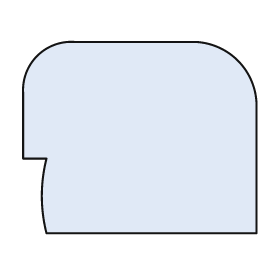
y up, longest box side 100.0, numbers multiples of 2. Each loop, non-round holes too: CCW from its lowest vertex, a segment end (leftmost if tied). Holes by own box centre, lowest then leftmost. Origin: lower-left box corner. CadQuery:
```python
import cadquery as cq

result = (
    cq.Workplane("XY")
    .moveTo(10.0, 0.0)
    .lineTo(100.0, 0.0)
    .lineTo(100.0, 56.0)
    .threePointArc((92.0, 74.0), (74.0, 82.0))
    .lineTo(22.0, 82.0)
    .threePointArc((6.0, 76.0), (0.0, 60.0))
    .lineTo(0.0, 32.0)
    .lineTo(10.0, 32.0)
    .threePointArc((8.0, 16.0), (10.0, 0.0))
    .close()
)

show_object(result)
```